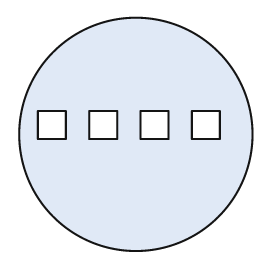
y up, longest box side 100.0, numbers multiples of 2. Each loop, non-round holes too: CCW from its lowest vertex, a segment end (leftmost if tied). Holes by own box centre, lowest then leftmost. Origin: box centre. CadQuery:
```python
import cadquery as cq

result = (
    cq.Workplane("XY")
    .moveTo(0.0, 0.0)
    .circle(50.0)
    .moveTo(-42.0, -2.0)
    .lineTo(-30.0, -2.0)
    .lineTo(-30.0, 10.0)
    .lineTo(-42.0, 10.0)
    .close()
    .moveTo(-20.0, -2.0)
    .lineTo(-8.0, -2.0)
    .lineTo(-8.0, 10.0)
    .lineTo(-20.0, 10.0)
    .close()
    .moveTo(2.0, -2.0)
    .lineTo(14.0, -2.0)
    .lineTo(14.0, 10.0)
    .lineTo(2.0, 10.0)
    .close()
    .moveTo(24.0, -2.0)
    .lineTo(36.0, -2.0)
    .lineTo(36.0, 10.0)
    .lineTo(24.0, 10.0)
    .close()
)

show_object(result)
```